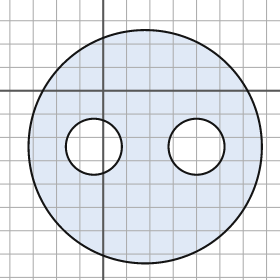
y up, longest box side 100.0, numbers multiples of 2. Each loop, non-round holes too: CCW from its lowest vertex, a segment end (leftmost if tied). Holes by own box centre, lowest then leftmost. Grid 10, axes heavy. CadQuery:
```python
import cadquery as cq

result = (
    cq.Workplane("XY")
    .moveTo(18.0, -24.0)
    .circle(50.0)
    .moveTo(-4.0, -24.0)
    .circle(12.0)
    .moveTo(40.0, -24.0)
    .circle(12.0)
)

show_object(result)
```